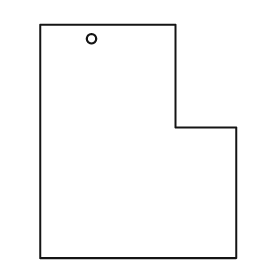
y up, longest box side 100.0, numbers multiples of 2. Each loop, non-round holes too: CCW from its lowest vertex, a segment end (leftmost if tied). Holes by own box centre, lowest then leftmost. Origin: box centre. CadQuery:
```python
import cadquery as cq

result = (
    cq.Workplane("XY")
    .moveTo(-42.0, -50.0)
    .lineTo(42.0, -50.0)
    .lineTo(42.0, 6.0)
    .lineTo(16.0, 6.0)
    .lineTo(16.0, 50.0)
    .lineTo(-42.0, 50.0)
    .close()
    .moveTo(-20.0, 44.0)
    .circle(2.0)
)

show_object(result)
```